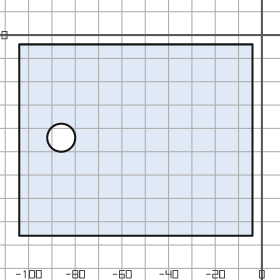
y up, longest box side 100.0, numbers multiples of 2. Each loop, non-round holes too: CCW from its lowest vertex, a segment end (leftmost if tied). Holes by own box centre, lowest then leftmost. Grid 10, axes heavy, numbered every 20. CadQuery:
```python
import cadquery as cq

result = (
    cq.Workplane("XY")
    .moveTo(-104.0, -86.0)
    .lineTo(-4.0, -86.0)
    .lineTo(-4.0, -4.0)
    .lineTo(-104.0, -4.0)
    .close()
    .moveTo(-86.0, -44.0)
    .circle(6.0)
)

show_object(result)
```